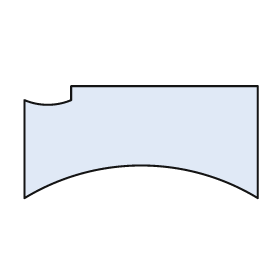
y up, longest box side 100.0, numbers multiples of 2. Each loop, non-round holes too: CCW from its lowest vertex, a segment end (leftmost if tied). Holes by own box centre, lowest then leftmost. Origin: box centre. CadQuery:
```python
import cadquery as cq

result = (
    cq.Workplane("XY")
    .moveTo(-50.0, -24.0)
    .threePointArc((0.0, -10.0), (50.0, -24.0))
    .lineTo(50.0, 24.0)
    .lineTo(-30.0, 24.0)
    .lineTo(-30.0, 18.0)
    .threePointArc((-40.0, 16.0), (-50.0, 18.0))
    .close()
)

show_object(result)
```